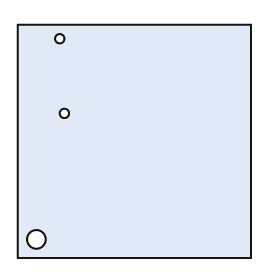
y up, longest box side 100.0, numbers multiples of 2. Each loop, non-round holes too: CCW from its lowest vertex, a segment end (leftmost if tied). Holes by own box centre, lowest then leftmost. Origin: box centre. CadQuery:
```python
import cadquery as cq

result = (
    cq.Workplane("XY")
    .moveTo(-50.0, -50.0)
    .lineTo(50.0, -50.0)
    .lineTo(50.0, 50.0)
    .lineTo(-50.0, 50.0)
    .close()
    .moveTo(-42.0, -42.0)
    .circle(4.0)
    .moveTo(-30.0, 12.0)
    .circle(2.0)
    .moveTo(-32.0, 44.0)
    .circle(2.0)
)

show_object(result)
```